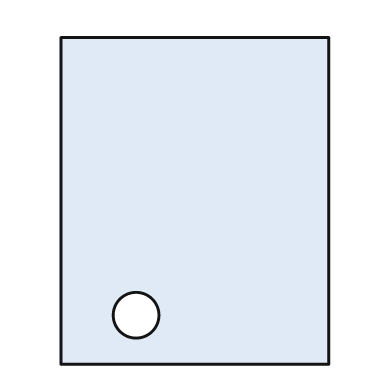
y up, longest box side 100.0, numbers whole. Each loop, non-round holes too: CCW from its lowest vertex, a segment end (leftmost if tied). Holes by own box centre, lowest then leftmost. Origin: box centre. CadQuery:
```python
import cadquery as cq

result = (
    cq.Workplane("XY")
    .moveTo(-41.0, -50.0)
    .lineTo(41.0, -50.0)
    .lineTo(41.0, 50.0)
    .lineTo(-41.0, 50.0)
    .close()
    .moveTo(-18.0, -35.0)
    .circle(7.0)
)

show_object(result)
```